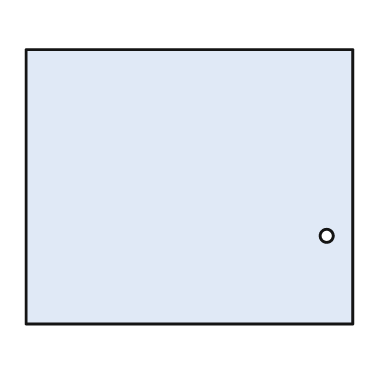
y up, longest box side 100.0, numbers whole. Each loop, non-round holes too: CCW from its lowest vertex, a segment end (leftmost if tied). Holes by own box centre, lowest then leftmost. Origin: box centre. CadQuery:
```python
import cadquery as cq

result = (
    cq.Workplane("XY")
    .moveTo(-50.0, -42.0)
    .lineTo(50.0, -42.0)
    .lineTo(50.0, 42.0)
    .lineTo(-50.0, 42.0)
    .close()
    .moveTo(42.0, -15.0)
    .circle(2.0)
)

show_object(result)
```